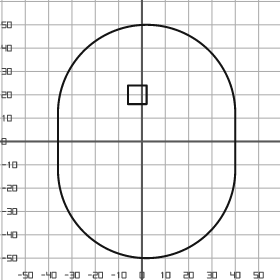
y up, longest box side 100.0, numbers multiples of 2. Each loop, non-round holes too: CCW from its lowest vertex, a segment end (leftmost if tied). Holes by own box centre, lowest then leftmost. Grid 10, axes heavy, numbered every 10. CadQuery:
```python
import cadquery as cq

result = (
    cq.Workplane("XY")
    .moveTo(-36.0, -12.0)
    .threePointArc((2.0, -50.0), (40.0, -12.0))
    .lineTo(40.0, 12.0)
    .threePointArc((2.0, 50.0), (-36.0, 12.0))
    .close()
    .moveTo(-6.0, 16.0)
    .lineTo(2.0, 16.0)
    .lineTo(2.0, 24.0)
    .lineTo(-6.0, 24.0)
    .close()
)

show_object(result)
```